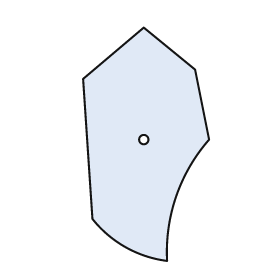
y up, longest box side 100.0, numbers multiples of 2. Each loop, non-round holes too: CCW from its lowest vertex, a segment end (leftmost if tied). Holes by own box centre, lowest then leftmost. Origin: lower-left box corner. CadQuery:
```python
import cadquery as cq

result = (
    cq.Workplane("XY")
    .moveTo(36.0, 0.0)
    .threePointArc((40.0, 28.0), (54.0, 52.0))
    .lineTo(48.0, 82.0)
    .lineTo(26.0, 100.0)
    .lineTo(0.0, 78.0)
    .lineTo(4.0, 18.0)
    .threePointArc((18.0, 6.0), (36.0, 0.0))
    .close()
    .moveTo(26.0, 52.0)
    .circle(2.0)
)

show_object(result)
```